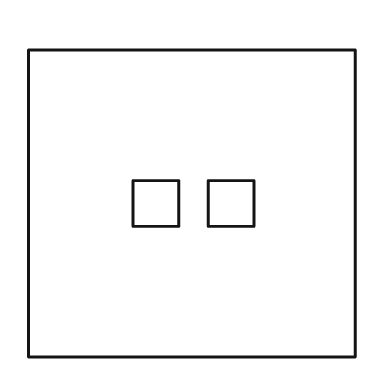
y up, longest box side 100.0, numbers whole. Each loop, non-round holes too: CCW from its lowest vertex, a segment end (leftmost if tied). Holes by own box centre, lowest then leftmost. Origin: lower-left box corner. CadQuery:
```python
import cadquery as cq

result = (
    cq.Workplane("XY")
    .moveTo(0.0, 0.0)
    .lineTo(100.0, 0.0)
    .lineTo(100.0, 94.0)
    .lineTo(0.0, 94.0)
    .close()
    .moveTo(32.0, 40.0)
    .lineTo(46.0, 40.0)
    .lineTo(46.0, 54.0)
    .lineTo(32.0, 54.0)
    .close()
    .moveTo(55.0, 40.0)
    .lineTo(69.0, 40.0)
    .lineTo(69.0, 54.0)
    .lineTo(55.0, 54.0)
    .close()
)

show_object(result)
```